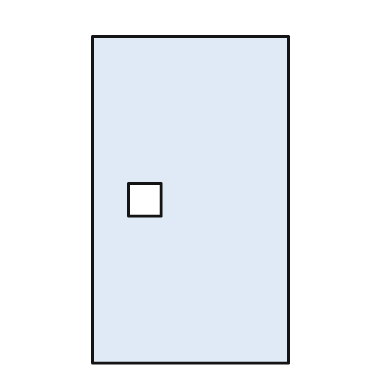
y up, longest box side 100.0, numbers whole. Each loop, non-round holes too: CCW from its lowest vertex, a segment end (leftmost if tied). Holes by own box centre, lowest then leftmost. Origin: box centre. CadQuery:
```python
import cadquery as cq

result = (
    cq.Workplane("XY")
    .moveTo(-30.0, -50.0)
    .lineTo(30.0, -50.0)
    .lineTo(30.0, 50.0)
    .lineTo(-30.0, 50.0)
    .close()
    .moveTo(-19.0, -5.0)
    .lineTo(-9.0, -5.0)
    .lineTo(-9.0, 5.0)
    .lineTo(-19.0, 5.0)
    .close()
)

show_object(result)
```